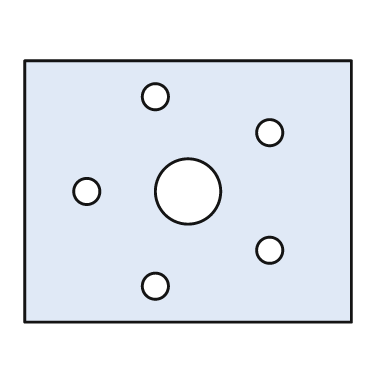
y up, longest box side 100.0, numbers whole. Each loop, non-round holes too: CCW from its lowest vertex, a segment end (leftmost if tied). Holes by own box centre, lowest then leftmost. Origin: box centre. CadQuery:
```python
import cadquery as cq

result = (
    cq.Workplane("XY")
    .moveTo(-50.0, -40.0)
    .lineTo(50.0, -40.0)
    .lineTo(50.0, 40.0)
    .lineTo(-50.0, 40.0)
    .close()
    .moveTo(-10.0, -29.0)
    .circle(4.0)
    .moveTo(25.0, -18.0)
    .circle(4.0)
    .moveTo(-31.0, 0.0)
    .circle(4.0)
    .moveTo(0.0, 0.0)
    .circle(10.0)
    .moveTo(25.0, 18.0)
    .circle(4.0)
    .moveTo(-10.0, 29.0)
    .circle(4.0)
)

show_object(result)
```